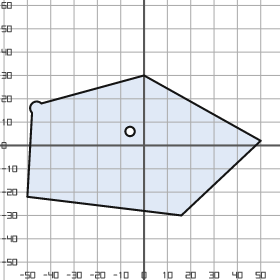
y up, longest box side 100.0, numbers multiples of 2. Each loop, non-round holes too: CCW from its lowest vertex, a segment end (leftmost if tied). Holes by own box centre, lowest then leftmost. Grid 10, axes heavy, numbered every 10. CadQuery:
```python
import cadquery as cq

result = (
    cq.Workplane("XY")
    .moveTo(16.0, -30.0)
    .lineTo(50.0, 2.0)
    .lineTo(0.0, 30.0)
    .lineTo(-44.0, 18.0)
    .threePointArc((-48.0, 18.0), (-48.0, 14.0))
    .lineTo(-50.0, -22.0)
    .close()
    .moveTo(-6.0, 6.0)
    .circle(2.0)
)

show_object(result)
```